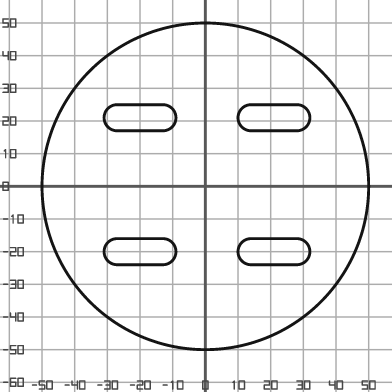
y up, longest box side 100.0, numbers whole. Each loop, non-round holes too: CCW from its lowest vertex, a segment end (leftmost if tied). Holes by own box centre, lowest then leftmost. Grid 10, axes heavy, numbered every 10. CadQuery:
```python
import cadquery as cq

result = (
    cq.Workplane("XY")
    .moveTo(0.0, 0.0)
    .circle(50.0)
    .moveTo(-27.0, -24.0)
    .lineTo(-13.0, -24.0)
    .threePointArc((-9.0, -20.0), (-13.0, -16.0))
    .lineTo(-27.0, -16.0)
    .threePointArc((-31.0, -20.0), (-27.0, -24.0))
    .close()
    .moveTo(14.0, -24.0)
    .lineTo(28.0, -24.0)
    .threePointArc((32.0, -20.0), (28.0, -16.0))
    .lineTo(14.0, -16.0)
    .threePointArc((10.0, -20.0), (14.0, -24.0))
    .close()
    .moveTo(-27.0, 17.0)
    .lineTo(-13.0, 17.0)
    .threePointArc((-9.0, 21.0), (-13.0, 25.0))
    .lineTo(-27.0, 25.0)
    .threePointArc((-31.0, 21.0), (-27.0, 17.0))
    .close()
    .moveTo(14.0, 17.0)
    .lineTo(28.0, 17.0)
    .threePointArc((32.0, 21.0), (28.0, 25.0))
    .lineTo(14.0, 25.0)
    .threePointArc((10.0, 21.0), (14.0, 17.0))
    .close()
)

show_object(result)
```